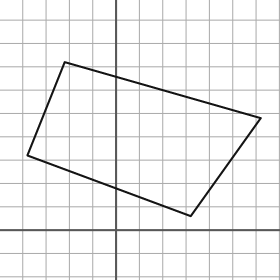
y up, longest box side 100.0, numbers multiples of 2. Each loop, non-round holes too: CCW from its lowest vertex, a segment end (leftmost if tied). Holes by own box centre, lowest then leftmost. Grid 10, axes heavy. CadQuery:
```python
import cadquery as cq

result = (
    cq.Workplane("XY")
    .moveTo(32.0, 6.0)
    .lineTo(62.0, 48.0)
    .lineTo(-22.0, 72.0)
    .lineTo(-38.0, 32.0)
    .close()
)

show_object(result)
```